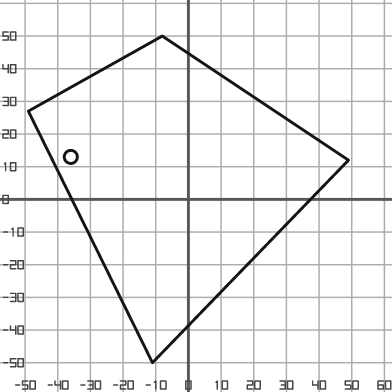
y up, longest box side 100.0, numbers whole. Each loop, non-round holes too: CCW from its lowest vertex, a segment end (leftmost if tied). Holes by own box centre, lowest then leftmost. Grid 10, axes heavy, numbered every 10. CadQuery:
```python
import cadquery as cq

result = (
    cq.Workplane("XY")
    .moveTo(-11.0, -50.0)
    .lineTo(49.0, 12.0)
    .lineTo(-8.0, 50.0)
    .lineTo(-49.0, 27.0)
    .close()
    .moveTo(-36.0, 13.0)
    .circle(2.0)
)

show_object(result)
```